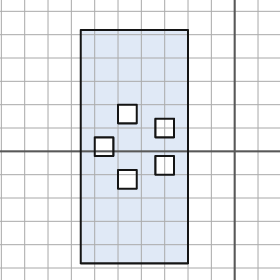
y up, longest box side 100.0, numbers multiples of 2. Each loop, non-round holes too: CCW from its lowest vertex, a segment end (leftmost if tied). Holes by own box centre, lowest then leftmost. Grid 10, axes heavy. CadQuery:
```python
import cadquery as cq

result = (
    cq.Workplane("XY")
    .moveTo(-66.0, -48.0)
    .lineTo(-20.0, -48.0)
    .lineTo(-20.0, 52.0)
    .lineTo(-66.0, 52.0)
    .close()
    .moveTo(-50.0, -16.0)
    .lineTo(-42.0, -16.0)
    .lineTo(-42.0, -8.0)
    .lineTo(-50.0, -8.0)
    .close()
    .moveTo(-34.0, -10.0)
    .lineTo(-26.0, -10.0)
    .lineTo(-26.0, -2.0)
    .lineTo(-34.0, -2.0)
    .close()
    .moveTo(-60.0, -2.0)
    .lineTo(-52.0, -2.0)
    .lineTo(-52.0, 6.0)
    .lineTo(-60.0, 6.0)
    .close()
    .moveTo(-34.0, 6.0)
    .lineTo(-26.0, 6.0)
    .lineTo(-26.0, 14.0)
    .lineTo(-34.0, 14.0)
    .close()
    .moveTo(-50.0, 12.0)
    .lineTo(-42.0, 12.0)
    .lineTo(-42.0, 20.0)
    .lineTo(-50.0, 20.0)
    .close()
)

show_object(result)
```